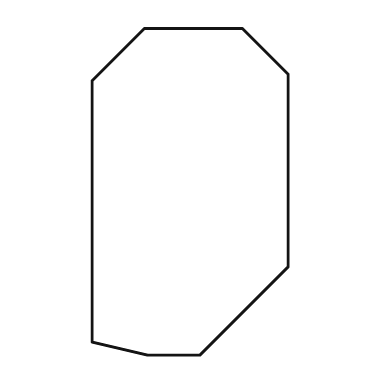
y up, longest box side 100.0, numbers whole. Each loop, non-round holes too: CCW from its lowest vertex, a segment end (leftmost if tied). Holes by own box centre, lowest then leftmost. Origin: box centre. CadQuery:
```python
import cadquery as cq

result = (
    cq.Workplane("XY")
    .moveTo(-13.0, -50.0)
    .lineTo(3.0, -50.0)
    .lineTo(30.0, -23.0)
    .lineTo(30.0, 36.0)
    .lineTo(16.0, 50.0)
    .lineTo(-14.0, 50.0)
    .lineTo(-30.0, 34.0)
    .lineTo(-30.0, -46.0)
    .close()
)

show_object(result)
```